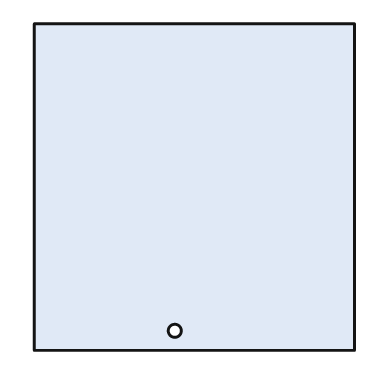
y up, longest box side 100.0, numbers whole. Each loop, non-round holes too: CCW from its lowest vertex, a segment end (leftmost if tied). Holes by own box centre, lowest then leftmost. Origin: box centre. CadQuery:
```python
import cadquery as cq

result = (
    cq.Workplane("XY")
    .moveTo(-49.0, -50.0)
    .lineTo(49.0, -50.0)
    .lineTo(49.0, 50.0)
    .lineTo(-49.0, 50.0)
    .close()
    .moveTo(-6.0, -44.0)
    .circle(2.0)
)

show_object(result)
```